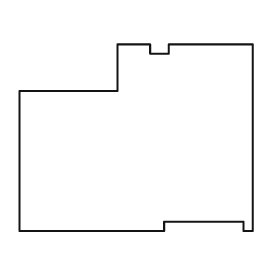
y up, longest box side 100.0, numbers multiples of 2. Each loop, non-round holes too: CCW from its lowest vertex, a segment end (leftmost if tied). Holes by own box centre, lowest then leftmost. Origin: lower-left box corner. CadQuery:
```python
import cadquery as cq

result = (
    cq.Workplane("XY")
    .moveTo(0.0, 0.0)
    .lineTo(62.0, 0.0)
    .lineTo(62.0, 4.0)
    .lineTo(96.0, 4.0)
    .lineTo(96.0, 0.0)
    .lineTo(100.0, 0.0)
    .lineTo(100.0, 80.0)
    .lineTo(64.0, 80.0)
    .lineTo(64.0, 76.0)
    .lineTo(56.0, 76.0)
    .lineTo(56.0, 80.0)
    .lineTo(42.0, 80.0)
    .lineTo(42.0, 60.0)
    .lineTo(0.0, 60.0)
    .close()
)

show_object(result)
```